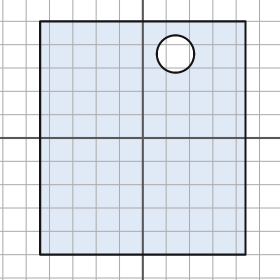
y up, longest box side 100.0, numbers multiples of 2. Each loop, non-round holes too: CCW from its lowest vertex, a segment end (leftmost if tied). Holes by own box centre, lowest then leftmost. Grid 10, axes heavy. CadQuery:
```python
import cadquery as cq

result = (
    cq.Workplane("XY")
    .moveTo(-44.0, -50.0)
    .lineTo(44.0, -50.0)
    .lineTo(44.0, 50.0)
    .lineTo(-44.0, 50.0)
    .close()
    .moveTo(14.0, 36.0)
    .circle(8.0)
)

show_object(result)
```